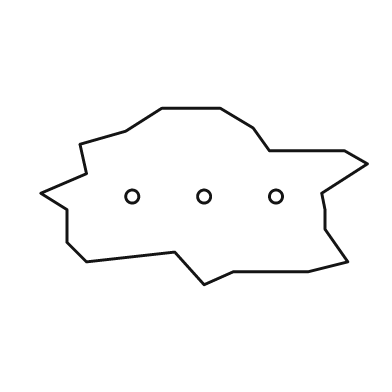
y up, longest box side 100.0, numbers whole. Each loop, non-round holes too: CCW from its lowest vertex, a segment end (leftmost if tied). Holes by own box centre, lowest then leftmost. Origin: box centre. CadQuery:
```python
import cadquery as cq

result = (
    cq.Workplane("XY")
    .moveTo(0.0, -27.0)
    .lineTo(9.0, -23.0)
    .lineTo(32.0, -23.0)
    .lineTo(44.0, -20.0)
    .lineTo(37.0, -10.0)
    .lineTo(37.0, -4.0)
    .lineTo(36.0, 1.0)
    .lineTo(50.0, 10.0)
    .lineTo(43.0, 14.0)
    .lineTo(20.0, 14.0)
    .lineTo(15.0, 21.0)
    .lineTo(5.0, 27.0)
    .lineTo(-13.0, 27.0)
    .lineTo(-24.0, 20.0)
    .lineTo(-38.0, 16.0)
    .lineTo(-36.0, 7.0)
    .lineTo(-50.0, 1.0)
    .lineTo(-42.0, -4.0)
    .lineTo(-42.0, -14.0)
    .lineTo(-36.0, -20.0)
    .lineTo(-9.0, -17.0)
    .close()
    .moveTo(-22.0, 0.0)
    .circle(2.0)
    .moveTo(0.0, 0.0)
    .circle(2.0)
    .moveTo(22.0, 0.0)
    .circle(2.0)
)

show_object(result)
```